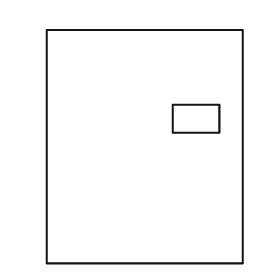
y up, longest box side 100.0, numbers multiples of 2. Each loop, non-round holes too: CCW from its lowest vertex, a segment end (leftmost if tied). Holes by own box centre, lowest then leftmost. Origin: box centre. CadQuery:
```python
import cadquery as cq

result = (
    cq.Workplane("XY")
    .moveTo(-42.0, -50.0)
    .lineTo(42.0, -50.0)
    .lineTo(42.0, 50.0)
    .lineTo(-42.0, 50.0)
    .close()
    .moveTo(12.0, 6.0)
    .lineTo(32.0, 6.0)
    .lineTo(32.0, 18.0)
    .lineTo(12.0, 18.0)
    .close()
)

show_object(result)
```